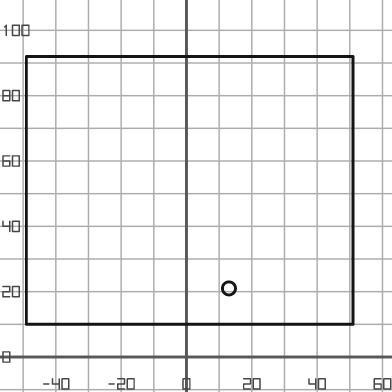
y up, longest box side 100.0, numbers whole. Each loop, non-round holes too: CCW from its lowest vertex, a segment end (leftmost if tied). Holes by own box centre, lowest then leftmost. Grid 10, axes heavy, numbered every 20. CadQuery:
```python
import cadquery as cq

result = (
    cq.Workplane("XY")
    .moveTo(-49.0, 10.0)
    .lineTo(51.0, 10.0)
    .lineTo(51.0, 92.0)
    .lineTo(-49.0, 92.0)
    .close()
    .moveTo(13.0, 21.0)
    .circle(2.0)
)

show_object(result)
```